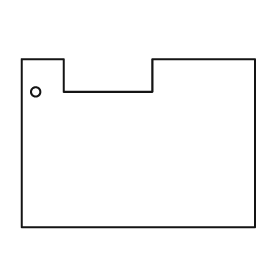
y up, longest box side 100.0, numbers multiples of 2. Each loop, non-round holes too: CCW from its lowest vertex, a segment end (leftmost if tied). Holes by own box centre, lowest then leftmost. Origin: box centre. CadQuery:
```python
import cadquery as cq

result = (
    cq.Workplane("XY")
    .moveTo(-50.0, -36.0)
    .lineTo(50.0, -36.0)
    .lineTo(50.0, 36.0)
    .lineTo(6.0, 36.0)
    .lineTo(6.0, 22.0)
    .lineTo(-32.0, 22.0)
    .lineTo(-32.0, 36.0)
    .lineTo(-50.0, 36.0)
    .close()
    .moveTo(-44.0, 22.0)
    .circle(2.0)
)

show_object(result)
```